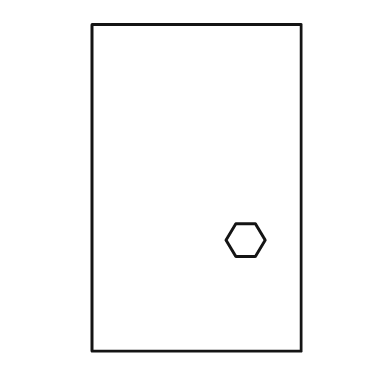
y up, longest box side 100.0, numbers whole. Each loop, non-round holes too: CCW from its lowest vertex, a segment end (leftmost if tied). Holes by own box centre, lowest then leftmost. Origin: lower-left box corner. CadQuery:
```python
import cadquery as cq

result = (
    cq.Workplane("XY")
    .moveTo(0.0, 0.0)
    .lineTo(64.0, 0.0)
    .lineTo(64.0, 100.0)
    .lineTo(0.0, 100.0)
    .close()
    .moveTo(44.0, 29.0)
    .lineTo(50.0, 29.0)
    .lineTo(53.0, 34.0)
    .lineTo(50.0, 39.0)
    .lineTo(44.0, 39.0)
    .lineTo(41.0, 34.0)
    .close()
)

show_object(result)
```